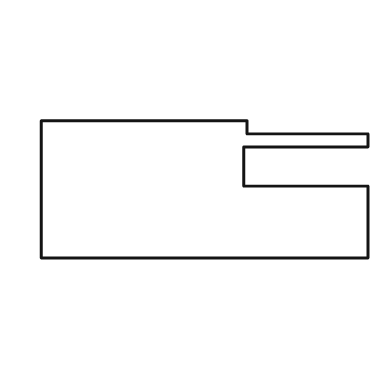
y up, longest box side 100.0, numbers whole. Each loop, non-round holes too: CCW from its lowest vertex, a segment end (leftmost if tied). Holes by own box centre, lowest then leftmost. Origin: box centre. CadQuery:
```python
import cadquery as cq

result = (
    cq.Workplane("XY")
    .moveTo(-50.0, -21.0)
    .lineTo(50.0, -21.0)
    .lineTo(50.0, 1.0)
    .lineTo(12.0, 1.0)
    .lineTo(12.0, 13.0)
    .lineTo(50.0, 13.0)
    .lineTo(50.0, 17.0)
    .lineTo(13.0, 17.0)
    .lineTo(13.0, 21.0)
    .lineTo(-50.0, 21.0)
    .close()
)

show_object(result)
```